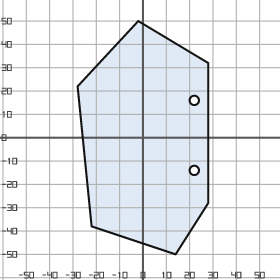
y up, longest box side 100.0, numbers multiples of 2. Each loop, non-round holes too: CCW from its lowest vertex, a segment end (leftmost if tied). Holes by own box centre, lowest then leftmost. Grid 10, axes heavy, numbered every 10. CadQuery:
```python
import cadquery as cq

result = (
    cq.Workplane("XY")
    .moveTo(14.0, -50.0)
    .lineTo(28.0, -28.0)
    .lineTo(28.0, 32.0)
    .lineTo(-2.0, 50.0)
    .lineTo(-28.0, 22.0)
    .lineTo(-22.0, -38.0)
    .close()
    .moveTo(22.0, -14.0)
    .circle(2.0)
    .moveTo(22.0, 16.0)
    .circle(2.0)
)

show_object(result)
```